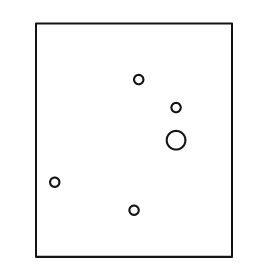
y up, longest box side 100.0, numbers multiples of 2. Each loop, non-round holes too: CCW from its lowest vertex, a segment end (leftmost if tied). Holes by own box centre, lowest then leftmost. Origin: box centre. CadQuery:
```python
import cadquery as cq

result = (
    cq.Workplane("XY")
    .moveTo(-42.0, -50.0)
    .lineTo(42.0, -50.0)
    .lineTo(42.0, 50.0)
    .lineTo(-42.0, 50.0)
    .close()
    .moveTo(0.0, -30.0)
    .circle(2.0)
    .moveTo(-34.0, -18.0)
    .circle(2.0)
    .moveTo(18.0, 0.0)
    .circle(4.0)
    .moveTo(18.0, 14.0)
    .circle(2.0)
    .moveTo(2.0, 26.0)
    .circle(2.0)
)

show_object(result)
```